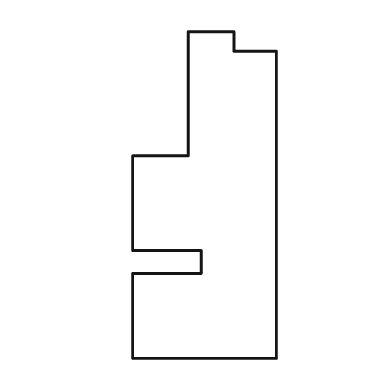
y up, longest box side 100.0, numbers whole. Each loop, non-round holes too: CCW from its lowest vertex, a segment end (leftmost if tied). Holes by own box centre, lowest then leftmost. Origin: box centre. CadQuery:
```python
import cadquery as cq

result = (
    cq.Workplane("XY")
    .moveTo(-22.0, -50.0)
    .lineTo(22.0, -50.0)
    .lineTo(22.0, 44.0)
    .lineTo(9.0, 44.0)
    .lineTo(9.0, 50.0)
    .lineTo(-5.0, 50.0)
    .lineTo(-5.0, 12.0)
    .lineTo(-22.0, 12.0)
    .lineTo(-22.0, -17.0)
    .lineTo(-1.0, -17.0)
    .lineTo(-1.0, -24.0)
    .lineTo(-22.0, -24.0)
    .close()
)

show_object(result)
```